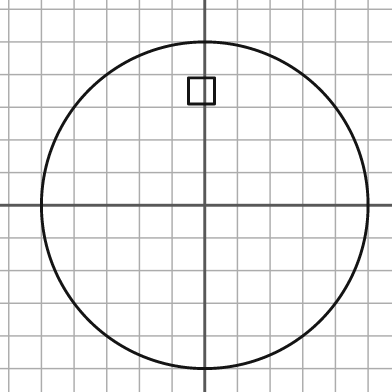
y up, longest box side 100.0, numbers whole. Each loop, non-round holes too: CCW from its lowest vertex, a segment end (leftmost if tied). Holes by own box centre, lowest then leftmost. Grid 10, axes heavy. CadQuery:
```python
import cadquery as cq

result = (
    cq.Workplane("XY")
    .moveTo(0.0, 0.0)
    .circle(50.0)
    .moveTo(-5.0, 31.0)
    .lineTo(3.0, 31.0)
    .lineTo(3.0, 39.0)
    .lineTo(-5.0, 39.0)
    .close()
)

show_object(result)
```